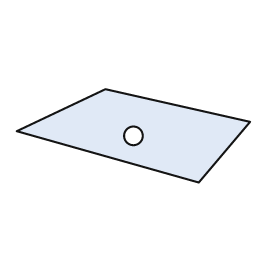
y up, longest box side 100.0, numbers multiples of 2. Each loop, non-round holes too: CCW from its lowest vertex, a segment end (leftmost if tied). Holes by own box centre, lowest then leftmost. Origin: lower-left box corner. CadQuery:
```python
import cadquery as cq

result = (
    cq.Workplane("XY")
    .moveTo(78.0, 0.0)
    .lineTo(100.0, 26.0)
    .lineTo(38.0, 40.0)
    .lineTo(0.0, 22.0)
    .close()
    .moveTo(50.0, 20.0)
    .circle(4.0)
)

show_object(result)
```